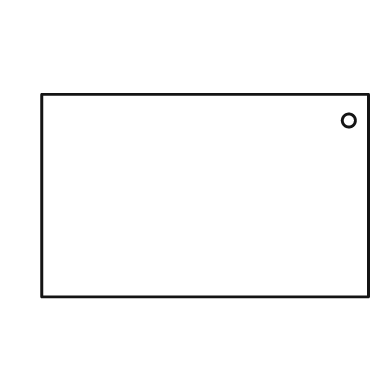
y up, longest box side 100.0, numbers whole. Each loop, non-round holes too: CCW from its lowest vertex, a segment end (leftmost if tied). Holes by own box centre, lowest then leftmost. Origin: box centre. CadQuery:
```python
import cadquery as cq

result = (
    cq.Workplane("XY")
    .moveTo(-50.0, -31.0)
    .lineTo(50.0, -31.0)
    .lineTo(50.0, 31.0)
    .lineTo(-50.0, 31.0)
    .close()
    .moveTo(44.0, 23.0)
    .circle(2.0)
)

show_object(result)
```